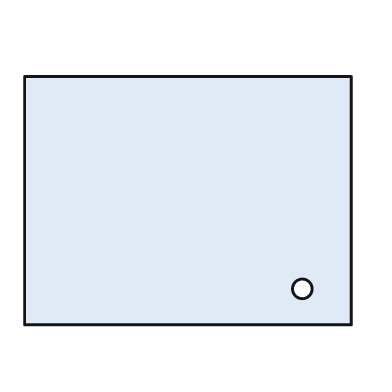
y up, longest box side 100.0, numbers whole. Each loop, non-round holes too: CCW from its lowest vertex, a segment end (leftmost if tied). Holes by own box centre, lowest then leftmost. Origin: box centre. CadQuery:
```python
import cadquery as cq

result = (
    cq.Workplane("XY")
    .moveTo(-50.0, -38.0)
    .lineTo(50.0, -38.0)
    .lineTo(50.0, 38.0)
    .lineTo(-50.0, 38.0)
    .close()
    .moveTo(35.0, -27.0)
    .circle(3.0)
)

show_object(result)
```